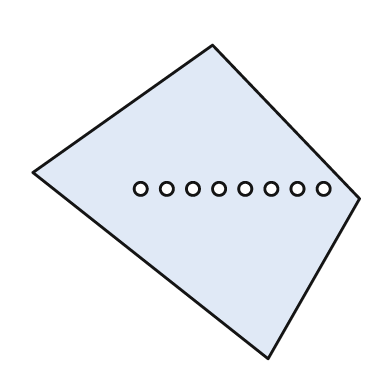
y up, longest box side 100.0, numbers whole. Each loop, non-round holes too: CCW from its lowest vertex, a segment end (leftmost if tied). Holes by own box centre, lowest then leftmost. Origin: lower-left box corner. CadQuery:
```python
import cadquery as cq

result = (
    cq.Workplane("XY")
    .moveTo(72.0, 0.0)
    .lineTo(100.0, 49.0)
    .lineTo(55.0, 96.0)
    .lineTo(0.0, 57.0)
    .close()
    .moveTo(33.0, 52.0)
    .circle(2.0)
    .moveTo(41.0, 52.0)
    .circle(2.0)
    .moveTo(49.0, 52.0)
    .circle(2.0)
    .moveTo(57.0, 52.0)
    .circle(2.0)
    .moveTo(65.0, 52.0)
    .circle(2.0)
    .moveTo(73.0, 52.0)
    .circle(2.0)
    .moveTo(81.0, 52.0)
    .circle(2.0)
    .moveTo(89.0, 52.0)
    .circle(2.0)
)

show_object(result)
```